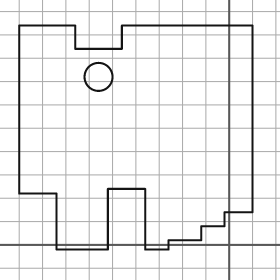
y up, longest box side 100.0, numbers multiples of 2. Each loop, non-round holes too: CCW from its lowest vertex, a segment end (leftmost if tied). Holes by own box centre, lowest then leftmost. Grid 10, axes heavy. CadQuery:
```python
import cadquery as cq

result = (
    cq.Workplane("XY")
    .moveTo(-74.0, -2.0)
    .lineTo(-52.0, -2.0)
    .lineTo(-52.0, 24.0)
    .lineTo(-36.0, 24.0)
    .lineTo(-36.0, -2.0)
    .lineTo(-26.0, -2.0)
    .lineTo(-26.0, 2.0)
    .lineTo(-12.0, 2.0)
    .lineTo(-12.0, 8.0)
    .lineTo(-2.0, 8.0)
    .lineTo(-2.0, 14.0)
    .lineTo(10.0, 14.0)
    .lineTo(10.0, 94.0)
    .lineTo(-46.0, 94.0)
    .lineTo(-46.0, 84.0)
    .lineTo(-66.0, 84.0)
    .lineTo(-66.0, 94.0)
    .lineTo(-90.0, 94.0)
    .lineTo(-90.0, 22.0)
    .lineTo(-74.0, 22.0)
    .close()
    .moveTo(-56.0, 72.0)
    .circle(6.0)
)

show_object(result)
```